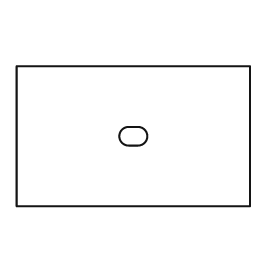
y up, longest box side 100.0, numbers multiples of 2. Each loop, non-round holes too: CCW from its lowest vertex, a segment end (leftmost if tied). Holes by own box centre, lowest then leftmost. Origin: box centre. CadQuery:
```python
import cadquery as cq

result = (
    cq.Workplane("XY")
    .moveTo(-50.0, -30.0)
    .lineTo(50.0, -30.0)
    .lineTo(50.0, 30.0)
    .lineTo(-50.0, 30.0)
    .close()
    .moveTo(-2.0, -4.0)
    .lineTo(2.0, -4.0)
    .threePointArc((6.0, 0.0), (2.0, 4.0))
    .lineTo(-2.0, 4.0)
    .threePointArc((-6.0, 0.0), (-2.0, -4.0))
    .close()
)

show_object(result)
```